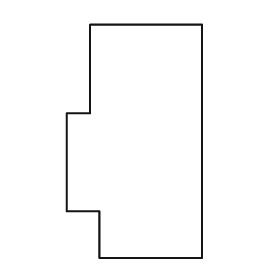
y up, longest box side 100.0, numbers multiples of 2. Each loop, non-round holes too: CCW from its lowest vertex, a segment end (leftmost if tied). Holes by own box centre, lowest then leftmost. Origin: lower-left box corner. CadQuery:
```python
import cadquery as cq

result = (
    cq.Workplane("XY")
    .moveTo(14.0, 0.0)
    .lineTo(58.0, 0.0)
    .lineTo(58.0, 100.0)
    .lineTo(10.0, 100.0)
    .lineTo(10.0, 62.0)
    .lineTo(0.0, 62.0)
    .lineTo(0.0, 20.0)
    .lineTo(14.0, 20.0)
    .close()
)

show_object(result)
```